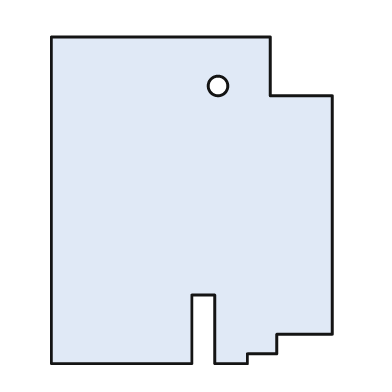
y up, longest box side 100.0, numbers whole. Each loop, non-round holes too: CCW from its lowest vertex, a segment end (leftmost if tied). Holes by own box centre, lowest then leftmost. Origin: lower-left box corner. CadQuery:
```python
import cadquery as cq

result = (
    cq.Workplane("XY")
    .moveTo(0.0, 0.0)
    .lineTo(43.0, 0.0)
    .lineTo(43.0, 21.0)
    .lineTo(50.0, 21.0)
    .lineTo(50.0, 0.0)
    .lineTo(60.0, 0.0)
    .lineTo(60.0, 3.0)
    .lineTo(69.0, 3.0)
    .lineTo(69.0, 9.0)
    .lineTo(86.0, 9.0)
    .lineTo(86.0, 82.0)
    .lineTo(67.0, 82.0)
    .lineTo(67.0, 100.0)
    .lineTo(0.0, 100.0)
    .close()
    .moveTo(51.0, 85.0)
    .circle(3.0)
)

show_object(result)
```